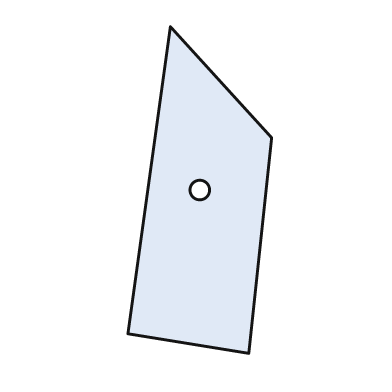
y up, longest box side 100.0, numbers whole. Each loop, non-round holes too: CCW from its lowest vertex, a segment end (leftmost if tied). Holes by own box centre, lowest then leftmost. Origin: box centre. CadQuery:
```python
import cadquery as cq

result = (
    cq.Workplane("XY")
    .moveTo(15.0, -50.0)
    .lineTo(22.0, 16.0)
    .lineTo(-9.0, 50.0)
    .lineTo(-22.0, -44.0)
    .close()
    .moveTo(0.0, 0.0)
    .circle(3.0)
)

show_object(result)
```